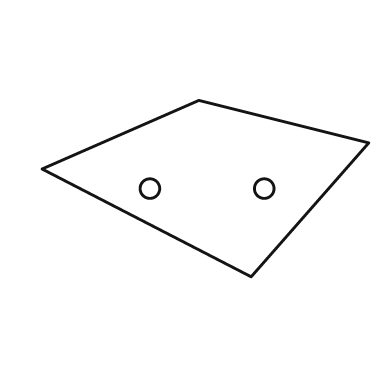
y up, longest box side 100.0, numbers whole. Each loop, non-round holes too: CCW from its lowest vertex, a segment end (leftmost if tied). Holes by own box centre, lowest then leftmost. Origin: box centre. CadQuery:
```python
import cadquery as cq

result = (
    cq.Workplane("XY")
    .moveTo(14.0, -27.0)
    .lineTo(50.0, 14.0)
    .lineTo(-2.0, 27.0)
    .lineTo(-50.0, 6.0)
    .close()
    .moveTo(-17.0, 0.0)
    .circle(3.0)
    .moveTo(18.0, 0.0)
    .circle(3.0)
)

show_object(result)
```